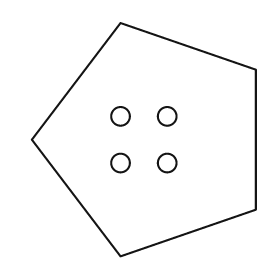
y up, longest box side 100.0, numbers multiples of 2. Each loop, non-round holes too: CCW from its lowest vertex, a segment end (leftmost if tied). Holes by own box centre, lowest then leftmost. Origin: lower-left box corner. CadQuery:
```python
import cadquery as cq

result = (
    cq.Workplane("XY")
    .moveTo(38.0, 0.0)
    .lineTo(96.0, 20.0)
    .lineTo(96.0, 80.0)
    .lineTo(38.0, 100.0)
    .lineTo(0.0, 50.0)
    .close()
    .moveTo(38.0, 40.0)
    .circle(4.0)
    .moveTo(58.0, 40.0)
    .circle(4.0)
    .moveTo(38.0, 60.0)
    .circle(4.0)
    .moveTo(58.0, 60.0)
    .circle(4.0)
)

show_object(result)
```